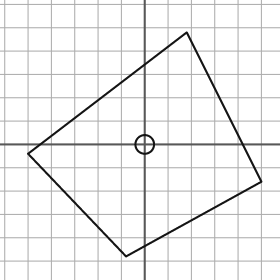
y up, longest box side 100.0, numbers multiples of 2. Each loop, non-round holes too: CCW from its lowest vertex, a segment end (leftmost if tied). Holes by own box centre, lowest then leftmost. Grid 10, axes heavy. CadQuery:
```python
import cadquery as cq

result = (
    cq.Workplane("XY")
    .moveTo(-8.0, -48.0)
    .lineTo(50.0, -16.0)
    .lineTo(18.0, 48.0)
    .lineTo(-50.0, -4.0)
    .close()
    .moveTo(0.0, 0.0)
    .circle(4.0)
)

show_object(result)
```